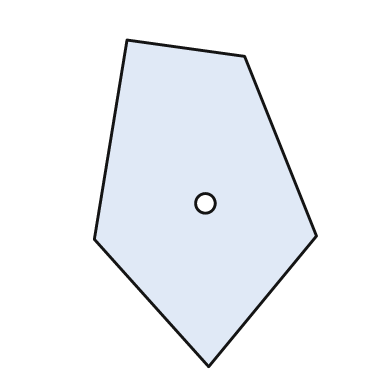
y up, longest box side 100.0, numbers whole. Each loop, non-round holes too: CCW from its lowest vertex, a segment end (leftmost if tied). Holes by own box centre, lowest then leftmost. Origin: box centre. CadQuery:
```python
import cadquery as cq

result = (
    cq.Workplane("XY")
    .moveTo(1.0, -50.0)
    .lineTo(34.0, -10.0)
    .lineTo(12.0, 45.0)
    .lineTo(-24.0, 50.0)
    .lineTo(-34.0, -11.0)
    .close()
    .moveTo(0.0, 0.0)
    .circle(3.0)
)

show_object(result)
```